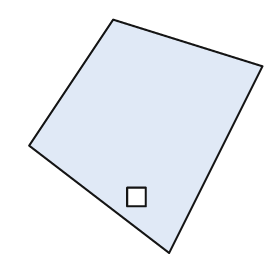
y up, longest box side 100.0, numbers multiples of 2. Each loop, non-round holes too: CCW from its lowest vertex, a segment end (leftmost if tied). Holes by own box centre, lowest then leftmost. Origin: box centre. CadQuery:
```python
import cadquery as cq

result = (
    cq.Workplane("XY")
    .moveTo(10.0, -50.0)
    .lineTo(50.0, 30.0)
    .lineTo(-14.0, 50.0)
    .lineTo(-50.0, -4.0)
    .close()
    .moveTo(-8.0, -30.0)
    .lineTo(0.0, -30.0)
    .lineTo(0.0, -22.0)
    .lineTo(-8.0, -22.0)
    .close()
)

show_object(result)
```